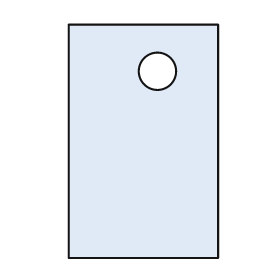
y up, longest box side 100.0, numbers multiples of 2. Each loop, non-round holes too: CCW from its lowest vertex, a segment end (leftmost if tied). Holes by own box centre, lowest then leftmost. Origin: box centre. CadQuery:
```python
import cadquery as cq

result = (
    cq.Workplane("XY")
    .moveTo(-32.0, -50.0)
    .lineTo(32.0, -50.0)
    .lineTo(32.0, 50.0)
    .lineTo(-32.0, 50.0)
    .close()
    .moveTo(6.0, 30.0)
    .circle(8.0)
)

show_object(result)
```